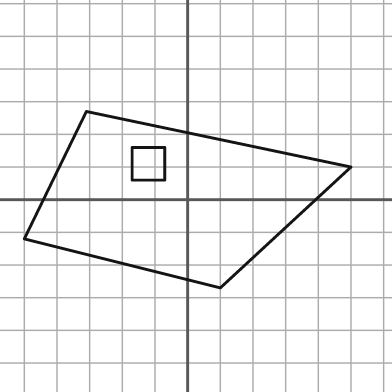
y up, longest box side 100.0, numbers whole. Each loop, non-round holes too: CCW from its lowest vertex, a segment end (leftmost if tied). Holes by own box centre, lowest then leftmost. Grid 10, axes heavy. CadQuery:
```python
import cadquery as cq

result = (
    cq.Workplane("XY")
    .moveTo(10.0, -27.0)
    .lineTo(50.0, 10.0)
    .lineTo(-31.0, 27.0)
    .lineTo(-50.0, -12.0)
    .close()
    .moveTo(-17.0, 6.0)
    .lineTo(-7.0, 6.0)
    .lineTo(-7.0, 16.0)
    .lineTo(-17.0, 16.0)
    .close()
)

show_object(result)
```